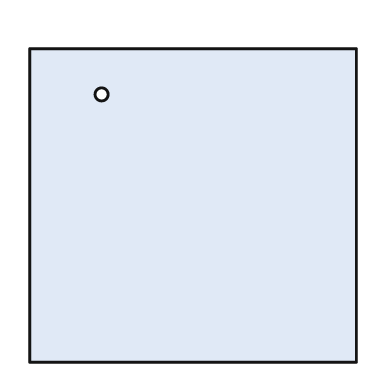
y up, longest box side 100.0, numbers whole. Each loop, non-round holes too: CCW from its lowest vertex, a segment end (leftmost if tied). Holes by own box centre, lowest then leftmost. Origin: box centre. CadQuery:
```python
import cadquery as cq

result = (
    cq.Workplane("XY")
    .moveTo(-50.0, -48.0)
    .lineTo(50.0, -48.0)
    .lineTo(50.0, 48.0)
    .lineTo(-50.0, 48.0)
    .close()
    .moveTo(-28.0, 34.0)
    .circle(2.0)
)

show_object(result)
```